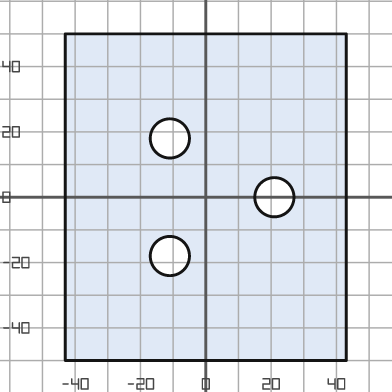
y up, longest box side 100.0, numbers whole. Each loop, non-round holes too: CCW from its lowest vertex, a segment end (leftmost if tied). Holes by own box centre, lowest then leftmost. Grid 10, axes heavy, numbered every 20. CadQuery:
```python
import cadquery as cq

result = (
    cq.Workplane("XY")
    .moveTo(-43.0, -50.0)
    .lineTo(43.0, -50.0)
    .lineTo(43.0, 50.0)
    .lineTo(-43.0, 50.0)
    .close()
    .moveTo(-11.0, -18.0)
    .circle(6.0)
    .moveTo(21.0, 0.0)
    .circle(6.0)
    .moveTo(-11.0, 18.0)
    .circle(6.0)
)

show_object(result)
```